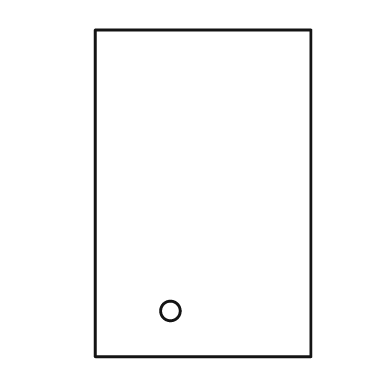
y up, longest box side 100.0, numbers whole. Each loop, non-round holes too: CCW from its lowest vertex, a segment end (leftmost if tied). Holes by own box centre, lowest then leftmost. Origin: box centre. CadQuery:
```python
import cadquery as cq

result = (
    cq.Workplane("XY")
    .moveTo(-33.0, -50.0)
    .lineTo(33.0, -50.0)
    .lineTo(33.0, 50.0)
    .lineTo(-33.0, 50.0)
    .close()
    .moveTo(-10.0, -36.0)
    .circle(3.0)
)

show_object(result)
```